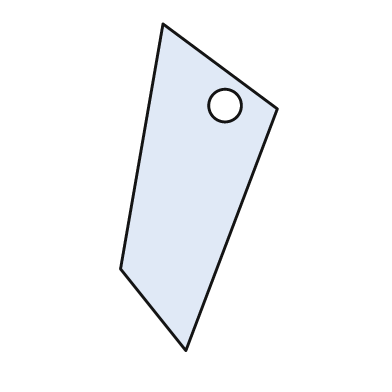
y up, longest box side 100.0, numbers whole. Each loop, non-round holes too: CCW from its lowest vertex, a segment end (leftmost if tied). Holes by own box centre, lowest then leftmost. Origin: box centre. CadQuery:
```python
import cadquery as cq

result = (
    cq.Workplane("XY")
    .moveTo(-4.0, -50.0)
    .lineTo(24.0, 24.0)
    .lineTo(-11.0, 50.0)
    .lineTo(-24.0, -25.0)
    .close()
    .moveTo(8.0, 25.0)
    .circle(5.0)
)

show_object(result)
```